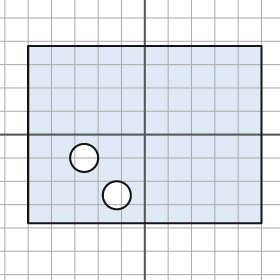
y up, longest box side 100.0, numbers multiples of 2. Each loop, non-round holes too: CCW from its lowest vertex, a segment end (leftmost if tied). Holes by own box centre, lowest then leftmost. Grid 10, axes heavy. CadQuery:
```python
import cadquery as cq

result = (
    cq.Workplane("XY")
    .moveTo(-50.0, -38.0)
    .lineTo(50.0, -38.0)
    .lineTo(50.0, 38.0)
    .lineTo(-50.0, 38.0)
    .close()
    .moveTo(-12.0, -26.0)
    .circle(6.0)
    .moveTo(-26.0, -10.0)
    .circle(6.0)
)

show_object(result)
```